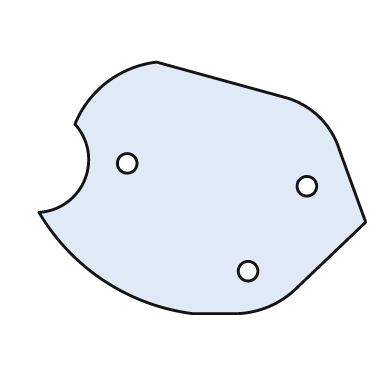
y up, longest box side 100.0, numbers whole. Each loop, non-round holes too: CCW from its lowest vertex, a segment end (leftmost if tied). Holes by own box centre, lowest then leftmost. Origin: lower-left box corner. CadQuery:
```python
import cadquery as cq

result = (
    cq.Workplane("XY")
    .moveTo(47.0, 0.0)
    .lineTo(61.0, 0.0)
    .threePointArc((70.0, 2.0), (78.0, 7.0))
    .lineTo(100.0, 28.0)
    .lineTo(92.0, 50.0)
    .threePointArc((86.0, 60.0), (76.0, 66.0))
    .lineTo(36.0, 77.0)
    .threePointArc((21.0, 71.0), (11.0, 58.0))
    .threePointArc((14.0, 41.0), (0.0, 31.0))
    .threePointArc((20.0, 10.0), (47.0, 0.0))
    .close()
    .moveTo(64.0, 13.0)
    .circle(3.0)
    .moveTo(82.0, 39.0)
    .circle(3.0)
    .moveTo(27.0, 46.0)
    .circle(3.0)
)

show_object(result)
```